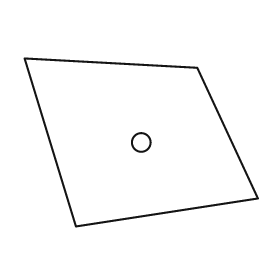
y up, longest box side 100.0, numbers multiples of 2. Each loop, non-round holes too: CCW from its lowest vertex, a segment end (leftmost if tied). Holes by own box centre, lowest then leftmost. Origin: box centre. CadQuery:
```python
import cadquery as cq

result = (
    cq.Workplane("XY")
    .moveTo(-28.0, -36.0)
    .lineTo(50.0, -24.0)
    .lineTo(24.0, 32.0)
    .lineTo(-50.0, 36.0)
    .close()
    .moveTo(0.0, 0.0)
    .circle(4.0)
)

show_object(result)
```